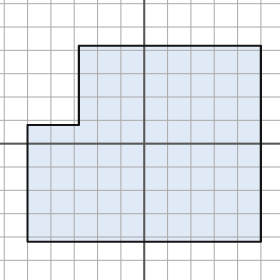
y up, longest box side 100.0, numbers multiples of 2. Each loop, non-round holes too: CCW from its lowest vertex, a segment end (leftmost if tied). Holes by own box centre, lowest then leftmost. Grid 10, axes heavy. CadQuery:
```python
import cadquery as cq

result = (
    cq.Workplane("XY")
    .moveTo(-50.0, -42.0)
    .lineTo(50.0, -42.0)
    .lineTo(50.0, 42.0)
    .lineTo(-28.0, 42.0)
    .lineTo(-28.0, 8.0)
    .lineTo(-50.0, 8.0)
    .close()
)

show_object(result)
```